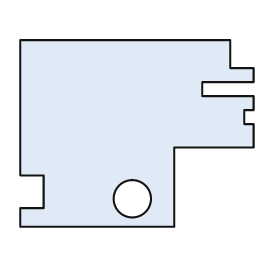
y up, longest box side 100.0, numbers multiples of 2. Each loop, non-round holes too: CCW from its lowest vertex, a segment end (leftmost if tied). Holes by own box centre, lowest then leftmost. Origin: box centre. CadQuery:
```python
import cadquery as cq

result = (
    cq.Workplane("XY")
    .moveTo(-50.0, -40.0)
    .lineTo(16.0, -40.0)
    .lineTo(16.0, -6.0)
    .lineTo(50.0, -6.0)
    .lineTo(50.0, 4.0)
    .lineTo(46.0, 4.0)
    .lineTo(46.0, 10.0)
    .lineTo(50.0, 10.0)
    .lineTo(50.0, 16.0)
    .lineTo(28.0, 16.0)
    .lineTo(28.0, 22.0)
    .lineTo(50.0, 22.0)
    .lineTo(50.0, 28.0)
    .lineTo(40.0, 28.0)
    .lineTo(40.0, 40.0)
    .lineTo(-50.0, 40.0)
    .lineTo(-50.0, -18.0)
    .lineTo(-40.0, -18.0)
    .lineTo(-40.0, -32.0)
    .lineTo(-50.0, -32.0)
    .close()
    .moveTo(-2.0, -28.0)
    .circle(8.0)
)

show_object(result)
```